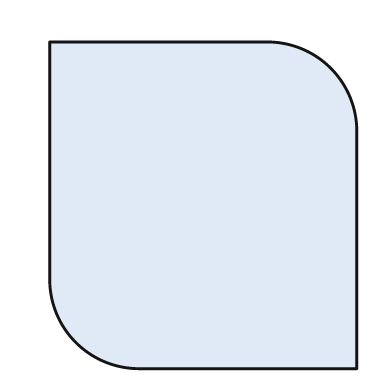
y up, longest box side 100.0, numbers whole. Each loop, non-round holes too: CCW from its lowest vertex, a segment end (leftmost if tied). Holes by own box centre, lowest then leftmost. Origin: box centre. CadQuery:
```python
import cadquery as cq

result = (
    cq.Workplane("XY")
    .moveTo(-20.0, -50.0)
    .lineTo(47.0, -50.0)
    .lineTo(47.0, 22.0)
    .threePointArc((39.0, 42.0), (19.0, 50.0))
    .lineTo(-47.0, 50.0)
    .lineTo(-47.0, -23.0)
    .threePointArc((-39.0, -42.0), (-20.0, -50.0))
    .close()
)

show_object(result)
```